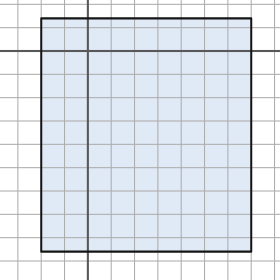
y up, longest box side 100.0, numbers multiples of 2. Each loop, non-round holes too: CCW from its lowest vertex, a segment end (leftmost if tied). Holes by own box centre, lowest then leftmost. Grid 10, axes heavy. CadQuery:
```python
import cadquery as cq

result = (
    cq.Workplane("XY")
    .moveTo(-20.0, -86.0)
    .lineTo(70.0, -86.0)
    .lineTo(70.0, 14.0)
    .lineTo(-20.0, 14.0)
    .close()
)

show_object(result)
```